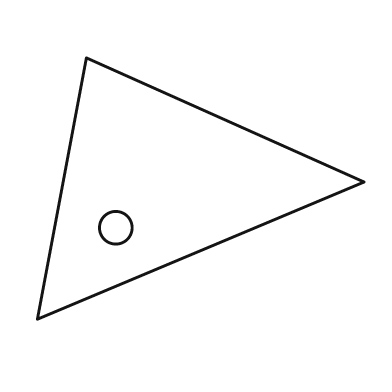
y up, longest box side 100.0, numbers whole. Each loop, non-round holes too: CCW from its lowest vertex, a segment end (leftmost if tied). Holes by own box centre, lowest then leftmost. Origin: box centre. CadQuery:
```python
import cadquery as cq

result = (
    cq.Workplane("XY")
    .moveTo(-50.0, -40.0)
    .lineTo(50.0, 2.0)
    .lineTo(-35.0, 40.0)
    .close()
    .moveTo(-26.0, -12.0)
    .circle(5.0)
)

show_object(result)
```